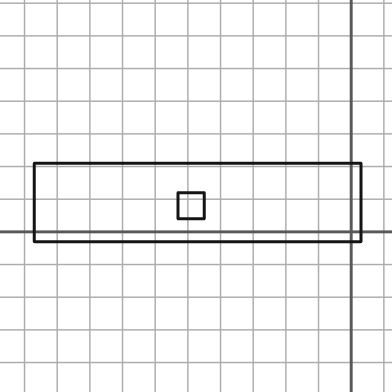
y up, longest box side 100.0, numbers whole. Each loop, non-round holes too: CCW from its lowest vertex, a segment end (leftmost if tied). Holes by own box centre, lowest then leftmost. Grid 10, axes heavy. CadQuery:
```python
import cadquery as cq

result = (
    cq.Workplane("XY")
    .moveTo(-97.0, -3.0)
    .lineTo(3.0, -3.0)
    .lineTo(3.0, 21.0)
    .lineTo(-97.0, 21.0)
    .close()
    .moveTo(-53.0, 4.0)
    .lineTo(-45.0, 4.0)
    .lineTo(-45.0, 12.0)
    .lineTo(-53.0, 12.0)
    .close()
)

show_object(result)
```